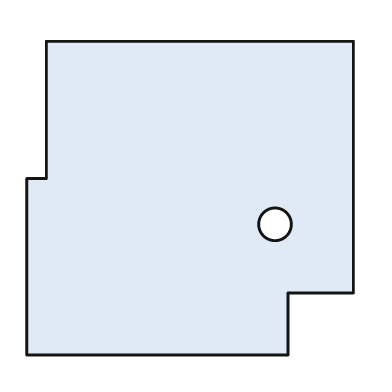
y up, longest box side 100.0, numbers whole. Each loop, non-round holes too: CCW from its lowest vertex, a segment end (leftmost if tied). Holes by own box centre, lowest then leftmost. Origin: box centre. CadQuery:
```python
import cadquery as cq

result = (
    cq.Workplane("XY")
    .moveTo(-50.0, -48.0)
    .lineTo(30.0, -48.0)
    .lineTo(30.0, -29.0)
    .lineTo(50.0, -29.0)
    .lineTo(50.0, 48.0)
    .lineTo(-44.0, 48.0)
    .lineTo(-44.0, 6.0)
    .lineTo(-50.0, 6.0)
    .close()
    .moveTo(26.0, -8.0)
    .circle(5.0)
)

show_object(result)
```